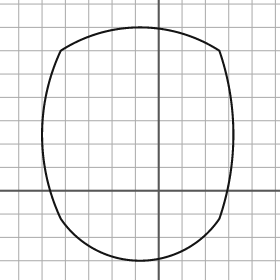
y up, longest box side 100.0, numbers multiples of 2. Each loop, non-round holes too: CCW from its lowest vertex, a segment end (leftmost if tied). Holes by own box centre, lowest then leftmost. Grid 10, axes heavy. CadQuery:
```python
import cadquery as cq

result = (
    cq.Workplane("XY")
    .moveTo(-42.0, -12.0)
    .threePointArc((-8.0, -30.0), (26.0, -12.0))
    .threePointArc((32.0, 24.0), (26.0, 60.0))
    .threePointArc((-8.0, 70.0), (-42.0, 60.0))
    .threePointArc((-50.0, 24.0), (-42.0, -12.0))
    .close()
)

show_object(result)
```